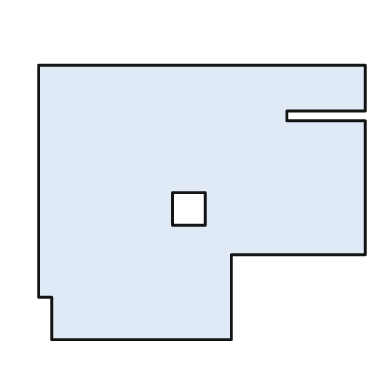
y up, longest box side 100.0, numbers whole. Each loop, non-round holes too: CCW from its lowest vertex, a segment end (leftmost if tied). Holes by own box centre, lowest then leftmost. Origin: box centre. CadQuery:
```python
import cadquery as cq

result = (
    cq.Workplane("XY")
    .moveTo(-46.0, -42.0)
    .lineTo(9.0, -42.0)
    .lineTo(9.0, -16.0)
    .lineTo(50.0, -16.0)
    .lineTo(50.0, 25.0)
    .lineTo(26.0, 25.0)
    .lineTo(26.0, 28.0)
    .lineTo(50.0, 28.0)
    .lineTo(50.0, 42.0)
    .lineTo(-50.0, 42.0)
    .lineTo(-50.0, -29.0)
    .lineTo(-46.0, -29.0)
    .close()
    .moveTo(-9.0, -7.0)
    .lineTo(1.0, -7.0)
    .lineTo(1.0, 3.0)
    .lineTo(-9.0, 3.0)
    .close()
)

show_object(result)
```